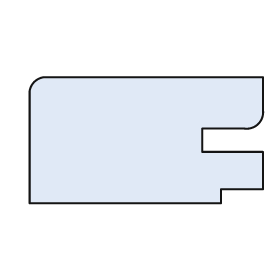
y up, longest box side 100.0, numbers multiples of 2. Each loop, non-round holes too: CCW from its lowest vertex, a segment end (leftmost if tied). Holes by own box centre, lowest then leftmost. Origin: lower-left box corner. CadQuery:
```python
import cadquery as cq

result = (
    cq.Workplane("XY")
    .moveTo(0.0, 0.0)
    .lineTo(82.0, 0.0)
    .lineTo(82.0, 6.0)
    .lineTo(100.0, 6.0)
    .lineTo(100.0, 22.0)
    .lineTo(74.0, 22.0)
    .lineTo(74.0, 32.0)
    .lineTo(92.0, 32.0)
    .threePointArc((98.0, 34.0), (100.0, 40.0))
    .lineTo(100.0, 54.0)
    .lineTo(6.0, 54.0)
    .threePointArc((2.0, 52.0), (0.0, 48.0))
    .close()
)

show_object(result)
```